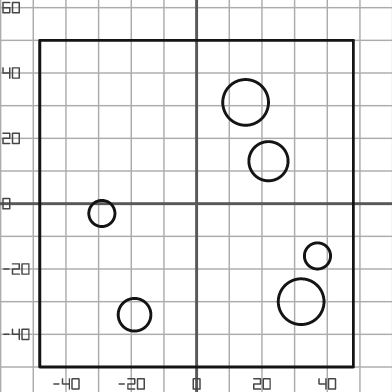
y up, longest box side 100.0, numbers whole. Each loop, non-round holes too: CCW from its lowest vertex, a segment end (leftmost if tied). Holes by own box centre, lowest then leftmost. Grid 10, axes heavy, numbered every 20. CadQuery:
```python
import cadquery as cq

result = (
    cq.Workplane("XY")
    .moveTo(-48.0, -50.0)
    .lineTo(48.0, -50.0)
    .lineTo(48.0, 50.0)
    .lineTo(-48.0, 50.0)
    .close()
    .moveTo(-19.0, -34.0)
    .circle(5.0)
    .moveTo(32.0, -30.0)
    .circle(7.0)
    .moveTo(37.0, -16.0)
    .circle(4.0)
    .moveTo(-29.0, -3.0)
    .circle(4.0)
    .moveTo(22.0, 13.0)
    .circle(6.0)
    .moveTo(15.0, 31.0)
    .circle(7.0)
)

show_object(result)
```